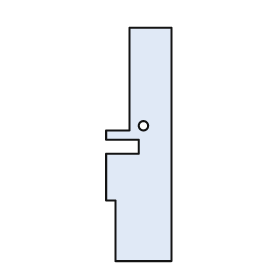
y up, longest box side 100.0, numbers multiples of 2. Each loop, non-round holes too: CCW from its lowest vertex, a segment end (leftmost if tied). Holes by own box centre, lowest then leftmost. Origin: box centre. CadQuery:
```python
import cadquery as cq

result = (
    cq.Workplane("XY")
    .moveTo(-10.0, -50.0)
    .lineTo(14.0, -50.0)
    .lineTo(14.0, 50.0)
    .lineTo(-4.0, 50.0)
    .lineTo(-4.0, 6.0)
    .lineTo(-14.0, 6.0)
    .lineTo(-14.0, 2.0)
    .lineTo(0.0, 2.0)
    .lineTo(0.0, -4.0)
    .lineTo(-14.0, -4.0)
    .lineTo(-14.0, -24.0)
    .lineTo(-10.0, -24.0)
    .close()
    .moveTo(2.0, 8.0)
    .circle(2.0)
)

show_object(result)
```